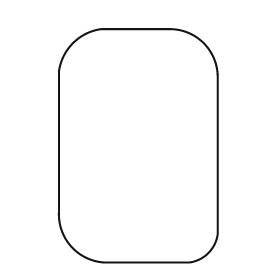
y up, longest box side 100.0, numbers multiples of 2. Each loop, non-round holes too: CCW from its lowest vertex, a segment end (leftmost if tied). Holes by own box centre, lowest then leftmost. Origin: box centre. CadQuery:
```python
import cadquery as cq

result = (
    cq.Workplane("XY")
    .moveTo(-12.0, -50.0)
    .lineTo(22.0, -50.0)
    .threePointArc((30.0, -46.0), (34.0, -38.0))
    .lineTo(34.0, 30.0)
    .threePointArc((28.0, 44.0), (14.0, 50.0))
    .lineTo(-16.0, 50.0)
    .threePointArc((-28.0, 44.0), (-34.0, 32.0))
    .lineTo(-34.0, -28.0)
    .threePointArc((-28.0, -44.0), (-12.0, -50.0))
    .close()
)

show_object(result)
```